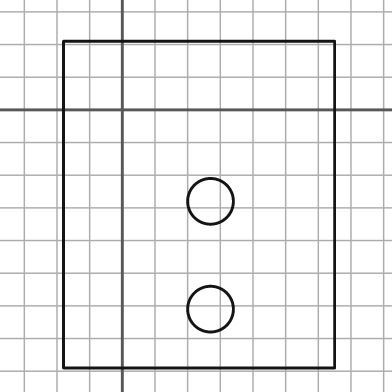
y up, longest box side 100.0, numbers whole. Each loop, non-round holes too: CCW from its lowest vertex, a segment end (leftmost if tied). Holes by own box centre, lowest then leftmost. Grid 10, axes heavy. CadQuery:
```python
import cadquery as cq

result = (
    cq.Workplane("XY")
    .moveTo(-18.0, -79.0)
    .lineTo(65.0, -79.0)
    .lineTo(65.0, 21.0)
    .lineTo(-18.0, 21.0)
    .close()
    .moveTo(27.0, -61.0)
    .circle(7.0)
    .moveTo(27.0, -28.0)
    .circle(7.0)
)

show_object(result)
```